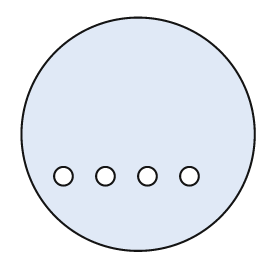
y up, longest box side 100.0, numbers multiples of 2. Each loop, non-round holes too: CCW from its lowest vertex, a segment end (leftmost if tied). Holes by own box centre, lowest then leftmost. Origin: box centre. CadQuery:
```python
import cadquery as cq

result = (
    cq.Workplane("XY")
    .moveTo(0.0, 0.0)
    .circle(50.0)
    .moveTo(-32.0, -18.0)
    .circle(4.0)
    .moveTo(-14.0, -18.0)
    .circle(4.0)
    .moveTo(4.0, -18.0)
    .circle(4.0)
    .moveTo(22.0, -18.0)
    .circle(4.0)
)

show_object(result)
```